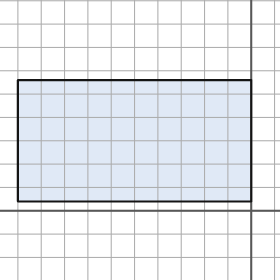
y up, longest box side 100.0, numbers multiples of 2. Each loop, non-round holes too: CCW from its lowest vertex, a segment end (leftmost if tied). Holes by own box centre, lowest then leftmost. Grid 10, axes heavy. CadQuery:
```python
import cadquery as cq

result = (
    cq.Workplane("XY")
    .moveTo(-100.0, 4.0)
    .lineTo(0.0, 4.0)
    .lineTo(0.0, 56.0)
    .lineTo(-100.0, 56.0)
    .close()
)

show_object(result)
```